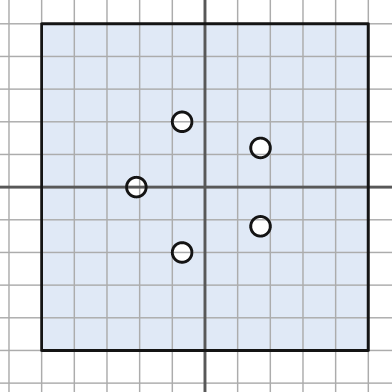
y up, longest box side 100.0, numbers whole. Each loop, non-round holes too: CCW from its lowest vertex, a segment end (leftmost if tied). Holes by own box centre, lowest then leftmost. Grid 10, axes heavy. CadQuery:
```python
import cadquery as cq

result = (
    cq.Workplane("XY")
    .moveTo(-50.0, -50.0)
    .lineTo(50.0, -50.0)
    .lineTo(50.0, 50.0)
    .lineTo(-50.0, 50.0)
    .close()
    .moveTo(-7.0, -20.0)
    .circle(3.0)
    .moveTo(17.0, -12.0)
    .circle(3.0)
    .moveTo(-21.0, 0.0)
    .circle(3.0)
    .moveTo(17.0, 12.0)
    .circle(3.0)
    .moveTo(-7.0, 20.0)
    .circle(3.0)
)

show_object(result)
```